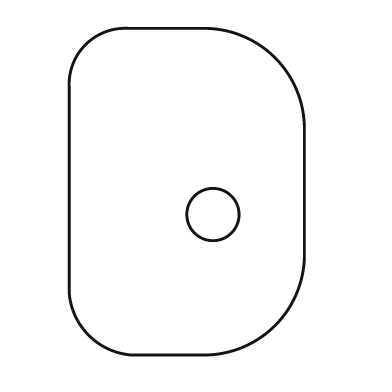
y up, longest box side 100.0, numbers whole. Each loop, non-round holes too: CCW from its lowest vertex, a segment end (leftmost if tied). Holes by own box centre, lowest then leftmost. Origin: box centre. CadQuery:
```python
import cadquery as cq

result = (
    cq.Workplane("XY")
    .moveTo(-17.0, -50.0)
    .lineTo(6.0, -50.0)
    .threePointArc((27.0, -41.0), (36.0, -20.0))
    .lineTo(36.0, 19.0)
    .threePointArc((27.0, 41.0), (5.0, 50.0))
    .lineTo(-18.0, 50.0)
    .threePointArc((-31.0, 45.0), (-36.0, 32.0))
    .lineTo(-36.0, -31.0)
    .threePointArc((-30.0, -44.0), (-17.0, -50.0))
    .close()
    .moveTo(8.0, -7.0)
    .circle(8.0)
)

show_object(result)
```